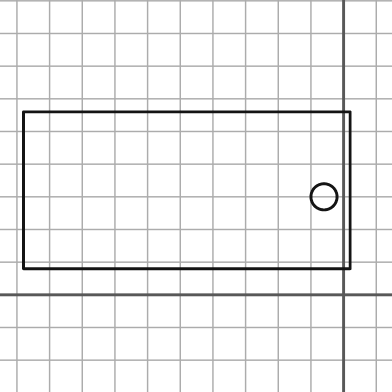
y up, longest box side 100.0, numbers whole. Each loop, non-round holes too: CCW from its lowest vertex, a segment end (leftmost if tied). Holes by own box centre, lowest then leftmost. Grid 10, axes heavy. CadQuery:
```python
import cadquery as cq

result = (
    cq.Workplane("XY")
    .moveTo(-98.0, 8.0)
    .lineTo(2.0, 8.0)
    .lineTo(2.0, 56.0)
    .lineTo(-98.0, 56.0)
    .close()
    .moveTo(-6.0, 30.0)
    .circle(4.0)
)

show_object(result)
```